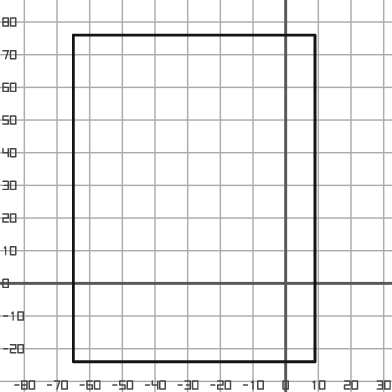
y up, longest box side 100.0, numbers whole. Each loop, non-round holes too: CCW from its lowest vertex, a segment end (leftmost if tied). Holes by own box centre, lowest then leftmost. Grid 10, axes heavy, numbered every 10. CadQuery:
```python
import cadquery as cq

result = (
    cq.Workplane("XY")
    .moveTo(-65.0, -24.0)
    .lineTo(9.0, -24.0)
    .lineTo(9.0, 76.0)
    .lineTo(-65.0, 76.0)
    .close()
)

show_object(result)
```